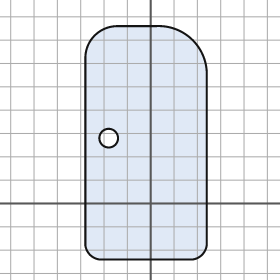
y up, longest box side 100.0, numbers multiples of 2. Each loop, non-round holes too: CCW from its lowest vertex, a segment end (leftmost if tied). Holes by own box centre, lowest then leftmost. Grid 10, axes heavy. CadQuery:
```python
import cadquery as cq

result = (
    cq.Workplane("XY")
    .moveTo(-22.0, -24.0)
    .lineTo(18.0, -24.0)
    .threePointArc((22.0, -22.0), (24.0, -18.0))
    .lineTo(24.0, 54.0)
    .threePointArc((18.0, 70.0), (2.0, 76.0))
    .lineTo(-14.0, 76.0)
    .threePointArc((-24.0, 72.0), (-28.0, 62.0))
    .lineTo(-28.0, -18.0)
    .threePointArc((-26.0, -22.0), (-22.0, -24.0))
    .close()
    .moveTo(-18.0, 28.0)
    .circle(4.0)
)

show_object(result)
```